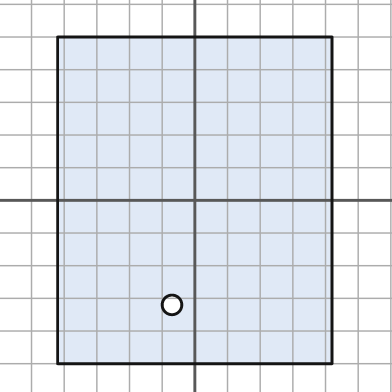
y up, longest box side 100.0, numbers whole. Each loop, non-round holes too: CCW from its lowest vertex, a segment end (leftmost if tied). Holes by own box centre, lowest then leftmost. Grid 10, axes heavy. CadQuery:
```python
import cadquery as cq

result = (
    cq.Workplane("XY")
    .moveTo(-42.0, -50.0)
    .lineTo(42.0, -50.0)
    .lineTo(42.0, 50.0)
    .lineTo(-42.0, 50.0)
    .close()
    .moveTo(-7.0, -32.0)
    .circle(3.0)
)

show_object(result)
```